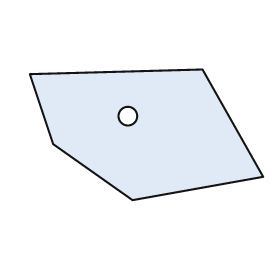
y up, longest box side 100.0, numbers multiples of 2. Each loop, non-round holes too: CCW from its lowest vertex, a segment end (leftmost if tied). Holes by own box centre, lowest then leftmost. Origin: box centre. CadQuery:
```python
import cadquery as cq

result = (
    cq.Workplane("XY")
    .moveTo(-6.0, -28.0)
    .lineTo(50.0, -18.0)
    .lineTo(24.0, 28.0)
    .lineTo(-50.0, 26.0)
    .lineTo(-40.0, -4.0)
    .close()
    .moveTo(-8.0, 8.0)
    .circle(4.0)
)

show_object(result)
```